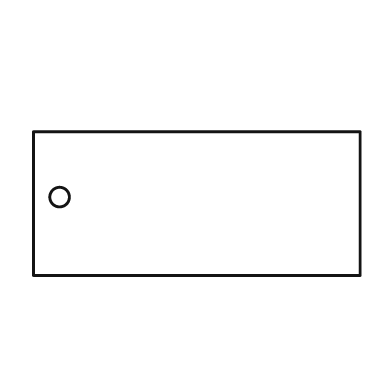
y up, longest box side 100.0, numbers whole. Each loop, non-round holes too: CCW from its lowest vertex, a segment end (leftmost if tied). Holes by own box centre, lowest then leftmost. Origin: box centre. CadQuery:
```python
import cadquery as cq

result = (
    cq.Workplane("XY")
    .moveTo(-50.0, -22.0)
    .lineTo(50.0, -22.0)
    .lineTo(50.0, 22.0)
    .lineTo(-50.0, 22.0)
    .close()
    .moveTo(-42.0, 2.0)
    .circle(3.0)
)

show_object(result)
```